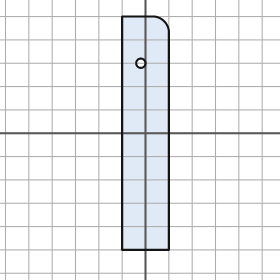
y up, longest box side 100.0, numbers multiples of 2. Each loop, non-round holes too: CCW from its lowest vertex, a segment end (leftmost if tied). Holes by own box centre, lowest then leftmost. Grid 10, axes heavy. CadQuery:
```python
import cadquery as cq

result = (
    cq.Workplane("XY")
    .moveTo(-10.0, -50.0)
    .lineTo(10.0, -50.0)
    .lineTo(10.0, 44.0)
    .threePointArc((8.0, 48.0), (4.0, 50.0))
    .lineTo(-10.0, 50.0)
    .close()
    .moveTo(-2.0, 30.0)
    .circle(2.0)
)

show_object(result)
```